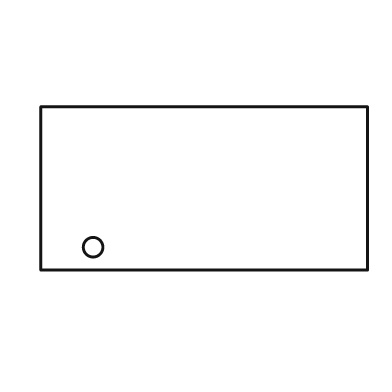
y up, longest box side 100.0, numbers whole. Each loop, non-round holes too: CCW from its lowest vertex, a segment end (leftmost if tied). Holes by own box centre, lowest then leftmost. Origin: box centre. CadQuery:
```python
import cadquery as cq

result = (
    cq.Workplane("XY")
    .moveTo(-50.0, -25.0)
    .lineTo(50.0, -25.0)
    .lineTo(50.0, 25.0)
    .lineTo(-50.0, 25.0)
    .close()
    .moveTo(-34.0, -18.0)
    .circle(3.0)
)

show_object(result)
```